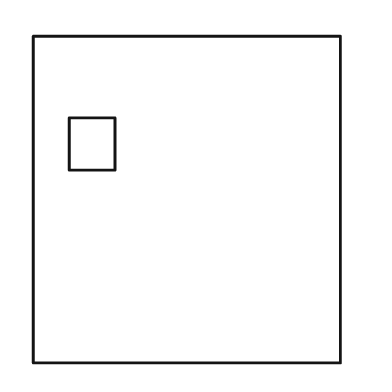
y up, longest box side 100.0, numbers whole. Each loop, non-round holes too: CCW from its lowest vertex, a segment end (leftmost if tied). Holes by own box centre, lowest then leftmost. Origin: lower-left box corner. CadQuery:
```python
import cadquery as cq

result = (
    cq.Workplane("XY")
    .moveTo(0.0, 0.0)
    .lineTo(94.0, 0.0)
    .lineTo(94.0, 100.0)
    .lineTo(0.0, 100.0)
    .close()
    .moveTo(11.0, 59.0)
    .lineTo(25.0, 59.0)
    .lineTo(25.0, 75.0)
    .lineTo(11.0, 75.0)
    .close()
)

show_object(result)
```